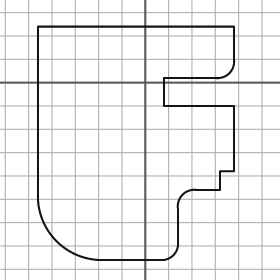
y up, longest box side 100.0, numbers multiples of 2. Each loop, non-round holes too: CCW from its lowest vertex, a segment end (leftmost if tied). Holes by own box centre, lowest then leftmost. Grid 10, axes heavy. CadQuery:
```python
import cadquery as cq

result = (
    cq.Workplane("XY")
    .moveTo(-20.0, -76.0)
    .lineTo(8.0, -76.0)
    .threePointArc((12.0, -74.0), (14.0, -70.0))
    .lineTo(14.0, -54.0)
    .threePointArc((16.0, -48.0), (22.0, -46.0))
    .lineTo(32.0, -46.0)
    .lineTo(32.0, -38.0)
    .lineTo(38.0, -38.0)
    .lineTo(38.0, -10.0)
    .lineTo(8.0, -10.0)
    .lineTo(8.0, 2.0)
    .lineTo(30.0, 2.0)
    .threePointArc((36.0, 4.0), (38.0, 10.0))
    .lineTo(38.0, 24.0)
    .lineTo(-46.0, 24.0)
    .lineTo(-46.0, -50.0)
    .threePointArc((-38.0, -68.0), (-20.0, -76.0))
    .close()
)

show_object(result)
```